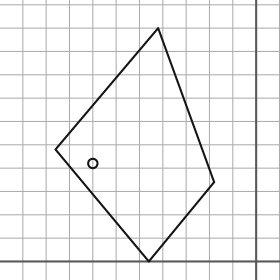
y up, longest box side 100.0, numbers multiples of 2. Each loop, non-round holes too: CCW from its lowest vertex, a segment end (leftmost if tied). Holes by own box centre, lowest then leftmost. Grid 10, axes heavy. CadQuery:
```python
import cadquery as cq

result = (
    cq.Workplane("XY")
    .moveTo(-46.0, 0.0)
    .lineTo(-18.0, 34.0)
    .lineTo(-42.0, 100.0)
    .lineTo(-86.0, 48.0)
    .close()
    .moveTo(-70.0, 42.0)
    .circle(2.0)
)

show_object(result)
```